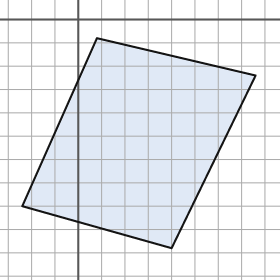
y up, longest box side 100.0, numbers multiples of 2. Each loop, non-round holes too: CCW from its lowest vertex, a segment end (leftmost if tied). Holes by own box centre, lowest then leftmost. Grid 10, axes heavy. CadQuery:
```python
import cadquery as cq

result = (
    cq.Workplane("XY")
    .moveTo(40.0, -98.0)
    .lineTo(76.0, -24.0)
    .lineTo(8.0, -8.0)
    .lineTo(-24.0, -80.0)
    .close()
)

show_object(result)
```